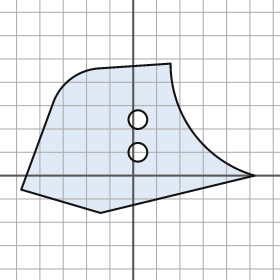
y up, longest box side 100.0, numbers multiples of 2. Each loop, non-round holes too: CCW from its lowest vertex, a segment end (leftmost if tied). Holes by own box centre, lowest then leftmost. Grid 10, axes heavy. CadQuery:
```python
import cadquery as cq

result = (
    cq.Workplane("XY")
    .moveTo(-14.0, -16.0)
    .lineTo(52.0, 0.0)
    .threePointArc((26.0, 18.0), (16.0, 48.0))
    .lineTo(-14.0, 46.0)
    .threePointArc((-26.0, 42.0), (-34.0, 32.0))
    .lineTo(-48.0, -6.0)
    .close()
    .moveTo(2.0, 10.0)
    .circle(4.0)
    .moveTo(2.0, 24.0)
    .circle(4.0)
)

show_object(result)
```